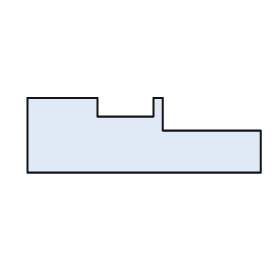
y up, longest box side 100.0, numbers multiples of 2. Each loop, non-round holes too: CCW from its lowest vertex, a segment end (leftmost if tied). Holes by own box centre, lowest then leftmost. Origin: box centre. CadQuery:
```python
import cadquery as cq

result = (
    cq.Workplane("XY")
    .moveTo(-50.0, -16.0)
    .lineTo(50.0, -16.0)
    .lineTo(50.0, 2.0)
    .lineTo(8.0, 2.0)
    .lineTo(8.0, 16.0)
    .lineTo(4.0, 16.0)
    .lineTo(4.0, 8.0)
    .lineTo(-20.0, 8.0)
    .lineTo(-20.0, 16.0)
    .lineTo(-50.0, 16.0)
    .close()
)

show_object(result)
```